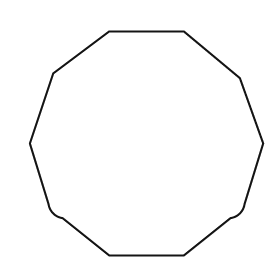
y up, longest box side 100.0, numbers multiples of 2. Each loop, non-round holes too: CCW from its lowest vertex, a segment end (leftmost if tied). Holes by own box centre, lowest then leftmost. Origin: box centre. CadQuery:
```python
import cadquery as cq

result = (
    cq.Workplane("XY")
    .moveTo(-16.0, -48.0)
    .lineTo(16.0, -48.0)
    .lineTo(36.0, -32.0)
    .threePointArc((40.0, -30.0), (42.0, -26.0))
    .lineTo(50.0, 0.0)
    .lineTo(40.0, 28.0)
    .lineTo(16.0, 48.0)
    .lineTo(-16.0, 48.0)
    .lineTo(-40.0, 30.0)
    .lineTo(-50.0, 0.0)
    .lineTo(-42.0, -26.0)
    .threePointArc((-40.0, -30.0), (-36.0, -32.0))
    .close()
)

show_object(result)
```